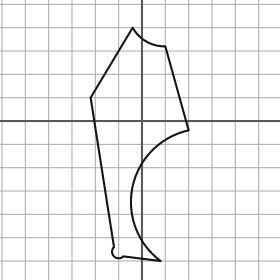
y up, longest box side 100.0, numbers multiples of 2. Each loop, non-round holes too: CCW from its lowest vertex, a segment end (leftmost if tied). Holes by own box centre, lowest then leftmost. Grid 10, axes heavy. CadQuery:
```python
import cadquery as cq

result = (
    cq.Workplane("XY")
    .moveTo(8.0, -60.0)
    .threePointArc((-4.0, -28.0), (20.0, -4.0))
    .lineTo(10.0, 32.0)
    .threePointArc((2.0, 34.0), (-4.0, 40.0))
    .lineTo(-22.0, 10.0)
    .lineTo(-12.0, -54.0)
    .threePointArc((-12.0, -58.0), (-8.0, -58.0))
    .close()
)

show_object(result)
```